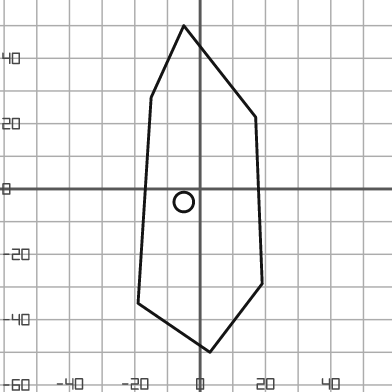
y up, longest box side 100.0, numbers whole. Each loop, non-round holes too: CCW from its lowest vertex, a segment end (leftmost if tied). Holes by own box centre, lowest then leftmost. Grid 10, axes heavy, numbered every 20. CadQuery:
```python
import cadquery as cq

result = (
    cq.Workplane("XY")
    .moveTo(3.0, -50.0)
    .lineTo(19.0, -29.0)
    .lineTo(17.0, 22.0)
    .lineTo(-5.0, 50.0)
    .lineTo(-15.0, 28.0)
    .lineTo(-19.0, -35.0)
    .close()
    .moveTo(-5.0, -4.0)
    .circle(3.0)
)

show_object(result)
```